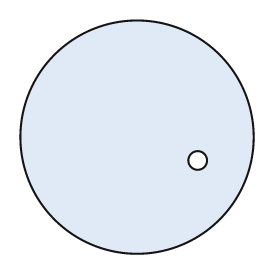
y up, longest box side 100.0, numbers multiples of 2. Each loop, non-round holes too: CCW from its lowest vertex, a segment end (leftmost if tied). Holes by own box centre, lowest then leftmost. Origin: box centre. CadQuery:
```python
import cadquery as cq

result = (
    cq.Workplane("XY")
    .moveTo(0.0, 0.0)
    .circle(50.0)
    .moveTo(26.0, -10.0)
    .circle(4.0)
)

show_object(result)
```